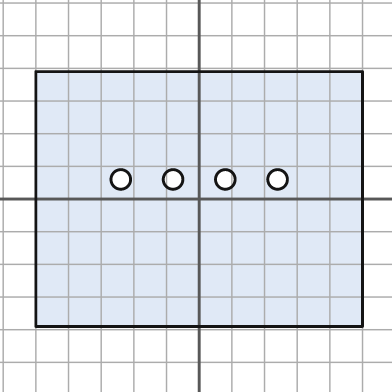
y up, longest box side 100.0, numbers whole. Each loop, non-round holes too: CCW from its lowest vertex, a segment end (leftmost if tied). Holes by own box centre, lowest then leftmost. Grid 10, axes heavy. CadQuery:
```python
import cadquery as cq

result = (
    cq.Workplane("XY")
    .moveTo(-50.0, -39.0)
    .lineTo(50.0, -39.0)
    .lineTo(50.0, 39.0)
    .lineTo(-50.0, 39.0)
    .close()
    .moveTo(-24.0, 6.0)
    .circle(3.0)
    .moveTo(-8.0, 6.0)
    .circle(3.0)
    .moveTo(8.0, 6.0)
    .circle(3.0)
    .moveTo(24.0, 6.0)
    .circle(3.0)
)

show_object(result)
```